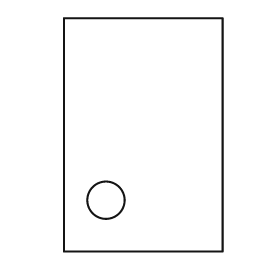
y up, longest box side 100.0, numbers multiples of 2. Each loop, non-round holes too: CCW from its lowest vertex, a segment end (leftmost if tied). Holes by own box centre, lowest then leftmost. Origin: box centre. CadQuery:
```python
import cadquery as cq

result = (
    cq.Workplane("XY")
    .moveTo(-34.0, -50.0)
    .lineTo(34.0, -50.0)
    .lineTo(34.0, 50.0)
    .lineTo(-34.0, 50.0)
    .close()
    .moveTo(-16.0, -28.0)
    .circle(8.0)
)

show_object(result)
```